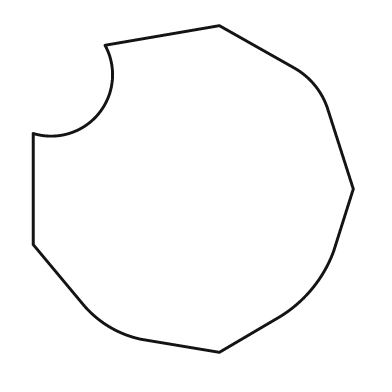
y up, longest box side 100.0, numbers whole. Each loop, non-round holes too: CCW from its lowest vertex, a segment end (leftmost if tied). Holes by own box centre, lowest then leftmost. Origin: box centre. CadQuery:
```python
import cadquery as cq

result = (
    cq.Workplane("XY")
    .moveTo(8.0, -50.0)
    .lineTo(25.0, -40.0)
    .threePointArc((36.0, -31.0), (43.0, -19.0))
    .lineTo(49.0, 0.0)
    .lineTo(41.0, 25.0)
    .threePointArc((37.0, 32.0), (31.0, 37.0))
    .lineTo(8.0, 50.0)
    .lineTo(-27.0, 44.0)
    .threePointArc((-29.0, 23.0), (-49.0, 17.0))
    .lineTo(-49.0, -17.0)
    .lineTo(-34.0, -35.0)
    .threePointArc((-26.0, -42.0), (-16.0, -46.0))
    .close()
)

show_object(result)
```